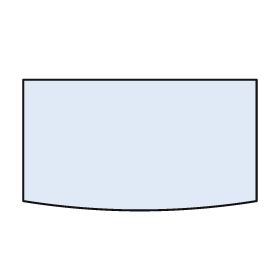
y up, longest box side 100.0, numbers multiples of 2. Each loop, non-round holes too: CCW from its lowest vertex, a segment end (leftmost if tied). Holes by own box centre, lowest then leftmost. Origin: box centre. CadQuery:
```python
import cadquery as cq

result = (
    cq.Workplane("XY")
    .moveTo(-50.0, -24.0)
    .threePointArc((0.0, -28.0), (50.0, -24.0))
    .lineTo(50.0, 28.0)
    .lineTo(-50.0, 28.0)
    .close()
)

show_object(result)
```